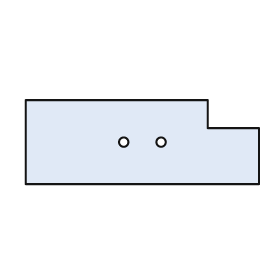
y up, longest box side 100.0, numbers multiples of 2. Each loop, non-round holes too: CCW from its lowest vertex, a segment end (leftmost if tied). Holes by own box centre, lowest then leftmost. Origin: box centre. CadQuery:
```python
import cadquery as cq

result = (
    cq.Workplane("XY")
    .moveTo(-50.0, -18.0)
    .lineTo(50.0, -18.0)
    .lineTo(50.0, 6.0)
    .lineTo(28.0, 6.0)
    .lineTo(28.0, 18.0)
    .lineTo(-50.0, 18.0)
    .close()
    .moveTo(-8.0, 0.0)
    .circle(2.0)
    .moveTo(8.0, 0.0)
    .circle(2.0)
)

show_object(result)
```